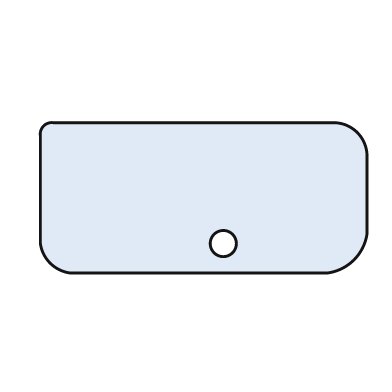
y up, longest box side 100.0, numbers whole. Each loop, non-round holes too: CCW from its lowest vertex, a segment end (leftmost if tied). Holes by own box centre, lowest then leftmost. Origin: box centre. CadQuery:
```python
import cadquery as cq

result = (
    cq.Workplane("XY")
    .moveTo(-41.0, -23.0)
    .lineTo(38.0, -23.0)
    .threePointArc((46.0, -19.0), (50.0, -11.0))
    .lineTo(50.0, 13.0)
    .threePointArc((47.0, 20.0), (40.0, 23.0))
    .lineTo(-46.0, 23.0)
    .threePointArc((-49.0, 22.0), (-50.0, 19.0))
    .lineTo(-50.0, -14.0)
    .threePointArc((-47.0, -20.0), (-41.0, -23.0))
    .close()
    .moveTo(6.0, -14.0)
    .circle(4.0)
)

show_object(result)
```